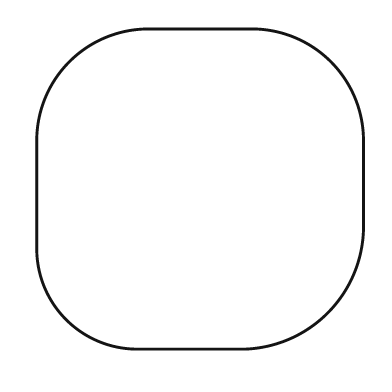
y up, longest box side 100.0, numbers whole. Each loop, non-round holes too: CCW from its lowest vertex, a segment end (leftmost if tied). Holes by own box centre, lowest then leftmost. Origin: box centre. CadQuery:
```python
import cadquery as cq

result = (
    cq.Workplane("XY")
    .moveTo(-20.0, -49.0)
    .lineTo(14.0, -49.0)
    .threePointArc((39.0, -38.0), (50.0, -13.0))
    .lineTo(50.0, 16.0)
    .threePointArc((40.0, 39.0), (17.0, 49.0))
    .lineTo(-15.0, 49.0)
    .threePointArc((-40.0, 39.0), (-50.0, 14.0))
    .lineTo(-50.0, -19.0)
    .threePointArc((-41.0, -40.0), (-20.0, -49.0))
    .close()
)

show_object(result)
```